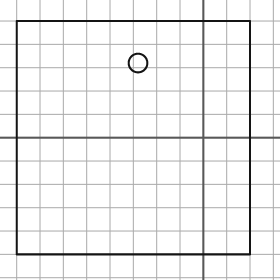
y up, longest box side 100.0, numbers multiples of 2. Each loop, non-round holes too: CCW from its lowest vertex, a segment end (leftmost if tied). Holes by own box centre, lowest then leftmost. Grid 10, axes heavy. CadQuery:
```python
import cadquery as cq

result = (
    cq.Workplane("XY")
    .moveTo(-80.0, -50.0)
    .lineTo(20.0, -50.0)
    .lineTo(20.0, 50.0)
    .lineTo(-80.0, 50.0)
    .close()
    .moveTo(-28.0, 32.0)
    .circle(4.0)
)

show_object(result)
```